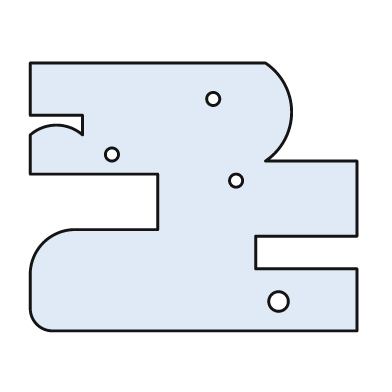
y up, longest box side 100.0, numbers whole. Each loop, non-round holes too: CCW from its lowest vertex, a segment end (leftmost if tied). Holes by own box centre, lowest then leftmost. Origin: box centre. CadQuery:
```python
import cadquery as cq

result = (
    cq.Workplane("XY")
    .moveTo(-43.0, -41.0)
    .lineTo(50.0, -41.0)
    .lineTo(50.0, -22.0)
    .lineTo(19.0, -22.0)
    .lineTo(19.0, -12.0)
    .lineTo(50.0, -12.0)
    .lineTo(50.0, 11.0)
    .lineTo(22.0, 11.0)
    .threePointArc((30.0, 26.0), (22.0, 41.0))
    .lineTo(-50.0, 41.0)
    .lineTo(-50.0, 25.0)
    .lineTo(-34.0, 25.0)
    .lineTo(-34.0, 19.0)
    .threePointArc((-42.0, 22.0), (-50.0, 19.0))
    .lineTo(-50.0, 7.0)
    .lineTo(-11.0, 7.0)
    .lineTo(-11.0, -10.0)
    .lineTo(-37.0, -10.0)
    .threePointArc((-46.0, -14.0), (-50.0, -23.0))
    .lineTo(-50.0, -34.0)
    .threePointArc((-48.0, -39.0), (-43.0, -41.0))
    .close()
    .moveTo(26.0, -32.0)
    .circle(3.0)
    .moveTo(13.0, 5.0)
    .circle(2.0)
    .moveTo(-25.0, 13.0)
    .circle(2.0)
    .moveTo(6.0, 30.0)
    .circle(2.0)
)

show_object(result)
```